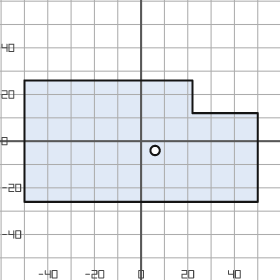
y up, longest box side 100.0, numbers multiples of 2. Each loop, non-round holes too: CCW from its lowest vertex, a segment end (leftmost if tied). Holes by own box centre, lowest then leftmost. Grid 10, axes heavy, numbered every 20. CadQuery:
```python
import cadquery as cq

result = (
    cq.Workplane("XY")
    .moveTo(-50.0, -26.0)
    .lineTo(50.0, -26.0)
    .lineTo(50.0, 12.0)
    .lineTo(22.0, 12.0)
    .lineTo(22.0, 26.0)
    .lineTo(-50.0, 26.0)
    .close()
    .moveTo(6.0, -4.0)
    .circle(2.0)
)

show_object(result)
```